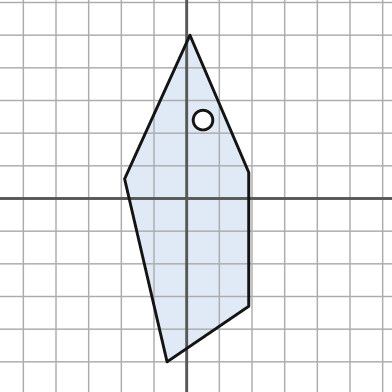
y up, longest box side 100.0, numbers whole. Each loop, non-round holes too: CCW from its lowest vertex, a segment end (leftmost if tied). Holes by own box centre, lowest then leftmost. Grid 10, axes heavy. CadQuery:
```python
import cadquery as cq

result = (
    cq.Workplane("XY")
    .moveTo(-6.0, -50.0)
    .lineTo(19.0, -33.0)
    .lineTo(19.0, 8.0)
    .lineTo(1.0, 50.0)
    .lineTo(-19.0, 6.0)
    .close()
    .moveTo(5.0, 24.0)
    .circle(3.0)
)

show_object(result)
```